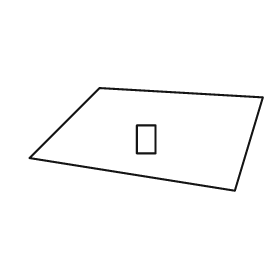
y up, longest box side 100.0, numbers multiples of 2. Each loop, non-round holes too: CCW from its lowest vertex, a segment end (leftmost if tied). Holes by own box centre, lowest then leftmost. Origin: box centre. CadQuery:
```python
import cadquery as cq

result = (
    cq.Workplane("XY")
    .moveTo(38.0, -22.0)
    .lineTo(50.0, 18.0)
    .lineTo(-20.0, 22.0)
    .lineTo(-50.0, -8.0)
    .close()
    .moveTo(-4.0, -6.0)
    .lineTo(4.0, -6.0)
    .lineTo(4.0, 6.0)
    .lineTo(-4.0, 6.0)
    .close()
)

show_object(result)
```